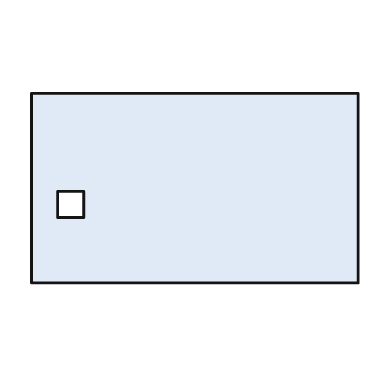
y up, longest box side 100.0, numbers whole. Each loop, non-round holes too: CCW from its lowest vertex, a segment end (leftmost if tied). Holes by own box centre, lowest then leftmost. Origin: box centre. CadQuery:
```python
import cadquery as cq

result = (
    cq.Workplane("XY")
    .moveTo(-50.0, -29.0)
    .lineTo(50.0, -29.0)
    .lineTo(50.0, 29.0)
    .lineTo(-50.0, 29.0)
    .close()
    .moveTo(-42.0, -9.0)
    .lineTo(-34.0, -9.0)
    .lineTo(-34.0, -1.0)
    .lineTo(-42.0, -1.0)
    .close()
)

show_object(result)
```